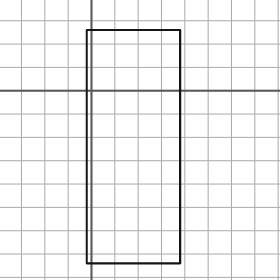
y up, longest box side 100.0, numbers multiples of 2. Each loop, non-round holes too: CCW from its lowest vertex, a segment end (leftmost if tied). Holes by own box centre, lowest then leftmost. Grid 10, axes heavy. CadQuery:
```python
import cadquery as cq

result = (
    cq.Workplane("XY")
    .moveTo(-2.0, -74.0)
    .lineTo(38.0, -74.0)
    .lineTo(38.0, 26.0)
    .lineTo(-2.0, 26.0)
    .close()
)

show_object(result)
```